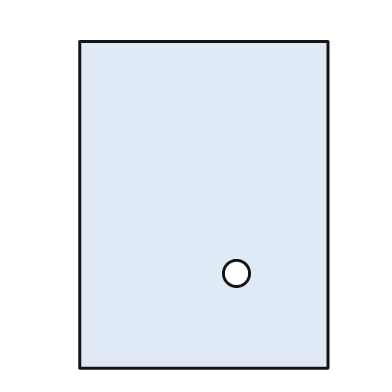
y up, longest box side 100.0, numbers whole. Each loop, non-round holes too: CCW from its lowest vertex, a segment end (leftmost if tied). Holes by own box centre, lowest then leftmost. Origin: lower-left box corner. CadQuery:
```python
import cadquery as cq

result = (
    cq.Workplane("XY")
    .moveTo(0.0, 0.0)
    .lineTo(76.0, 0.0)
    .lineTo(76.0, 100.0)
    .lineTo(0.0, 100.0)
    .close()
    .moveTo(48.0, 29.0)
    .circle(4.0)
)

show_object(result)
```